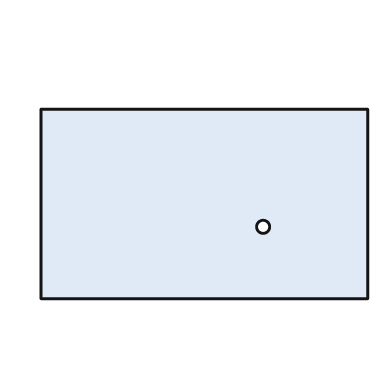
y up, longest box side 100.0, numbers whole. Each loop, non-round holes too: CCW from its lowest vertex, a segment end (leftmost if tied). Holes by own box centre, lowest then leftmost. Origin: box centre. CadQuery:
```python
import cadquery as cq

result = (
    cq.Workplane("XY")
    .moveTo(-50.0, -29.0)
    .lineTo(50.0, -29.0)
    .lineTo(50.0, 29.0)
    .lineTo(-50.0, 29.0)
    .close()
    .moveTo(18.0, -7.0)
    .circle(2.0)
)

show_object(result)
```